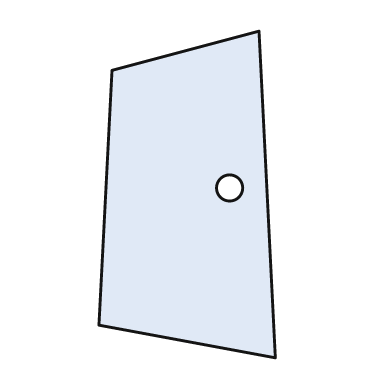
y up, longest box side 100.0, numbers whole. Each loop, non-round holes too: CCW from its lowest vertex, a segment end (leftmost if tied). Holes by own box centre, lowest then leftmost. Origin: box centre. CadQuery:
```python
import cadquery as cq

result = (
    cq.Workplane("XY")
    .moveTo(27.0, -50.0)
    .lineTo(22.0, 50.0)
    .lineTo(-23.0, 38.0)
    .lineTo(-27.0, -40.0)
    .close()
    .moveTo(13.0, 2.0)
    .circle(4.0)
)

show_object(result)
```